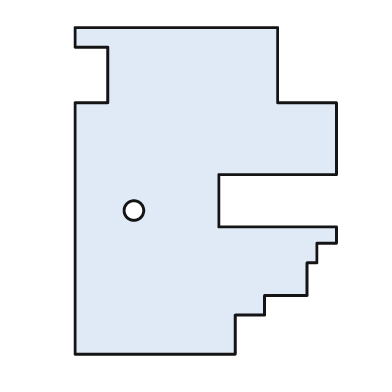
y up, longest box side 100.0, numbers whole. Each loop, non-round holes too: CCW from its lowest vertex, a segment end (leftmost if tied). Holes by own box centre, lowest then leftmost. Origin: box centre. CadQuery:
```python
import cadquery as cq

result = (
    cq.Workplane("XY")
    .moveTo(-40.0, -50.0)
    .lineTo(9.0, -50.0)
    .lineTo(9.0, -38.0)
    .lineTo(18.0, -38.0)
    .lineTo(18.0, -32.0)
    .lineTo(31.0, -32.0)
    .lineTo(31.0, -22.0)
    .lineTo(34.0, -22.0)
    .lineTo(34.0, -16.0)
    .lineTo(40.0, -16.0)
    .lineTo(40.0, -11.0)
    .lineTo(4.0, -11.0)
    .lineTo(4.0, 5.0)
    .lineTo(40.0, 5.0)
    .lineTo(40.0, 27.0)
    .lineTo(22.0, 27.0)
    .lineTo(22.0, 50.0)
    .lineTo(-40.0, 50.0)
    .lineTo(-40.0, 44.0)
    .lineTo(-30.0, 44.0)
    .lineTo(-30.0, 27.0)
    .lineTo(-40.0, 27.0)
    .close()
    .moveTo(-22.0, -6.0)
    .circle(3.0)
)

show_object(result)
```